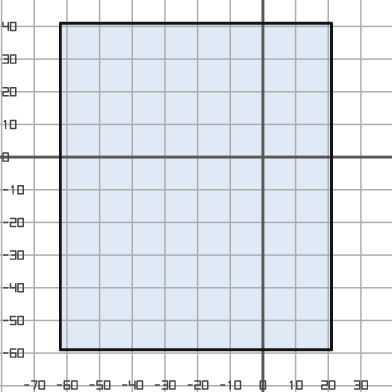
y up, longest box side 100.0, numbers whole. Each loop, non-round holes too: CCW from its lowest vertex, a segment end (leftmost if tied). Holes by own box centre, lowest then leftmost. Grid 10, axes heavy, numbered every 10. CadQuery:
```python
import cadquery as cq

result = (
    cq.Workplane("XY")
    .moveTo(-62.0, -59.0)
    .lineTo(21.0, -59.0)
    .lineTo(21.0, 41.0)
    .lineTo(-62.0, 41.0)
    .close()
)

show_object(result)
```